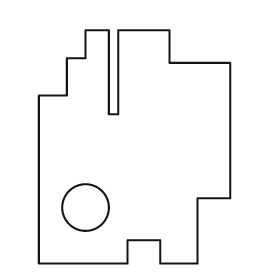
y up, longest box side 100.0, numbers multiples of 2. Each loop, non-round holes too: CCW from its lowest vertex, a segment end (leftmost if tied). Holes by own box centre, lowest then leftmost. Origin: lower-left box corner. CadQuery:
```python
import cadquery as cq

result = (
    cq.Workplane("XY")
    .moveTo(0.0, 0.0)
    .lineTo(38.0, 0.0)
    .lineTo(38.0, 10.0)
    .lineTo(52.0, 10.0)
    .lineTo(52.0, 0.0)
    .lineTo(68.0, 0.0)
    .lineTo(68.0, 28.0)
    .lineTo(82.0, 28.0)
    .lineTo(82.0, 86.0)
    .lineTo(56.0, 86.0)
    .lineTo(56.0, 100.0)
    .lineTo(34.0, 100.0)
    .lineTo(34.0, 64.0)
    .lineTo(30.0, 64.0)
    .lineTo(30.0, 100.0)
    .lineTo(20.0, 100.0)
    .lineTo(20.0, 88.0)
    .lineTo(12.0, 88.0)
    .lineTo(12.0, 72.0)
    .lineTo(0.0, 72.0)
    .close()
    .moveTo(20.0, 24.0)
    .circle(10.0)
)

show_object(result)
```